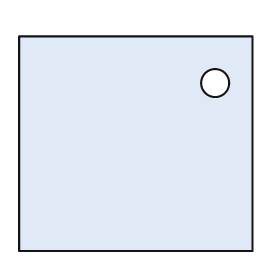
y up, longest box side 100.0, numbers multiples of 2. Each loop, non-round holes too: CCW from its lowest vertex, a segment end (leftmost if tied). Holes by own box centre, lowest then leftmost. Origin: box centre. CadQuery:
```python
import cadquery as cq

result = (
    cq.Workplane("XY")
    .moveTo(-50.0, -46.0)
    .lineTo(50.0, -46.0)
    .lineTo(50.0, 46.0)
    .lineTo(-50.0, 46.0)
    .close()
    .moveTo(34.0, 26.0)
    .circle(6.0)
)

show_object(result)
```